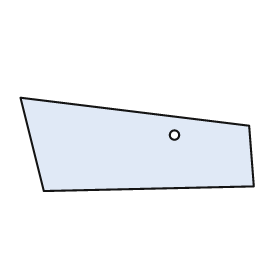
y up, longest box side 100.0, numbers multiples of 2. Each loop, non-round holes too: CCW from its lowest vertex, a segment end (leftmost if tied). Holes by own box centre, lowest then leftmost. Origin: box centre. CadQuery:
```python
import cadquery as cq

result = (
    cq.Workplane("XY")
    .moveTo(-40.0, -20.0)
    .lineTo(50.0, -18.0)
    .lineTo(48.0, 8.0)
    .lineTo(-50.0, 20.0)
    .close()
    .moveTo(16.0, 4.0)
    .circle(2.0)
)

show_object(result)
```